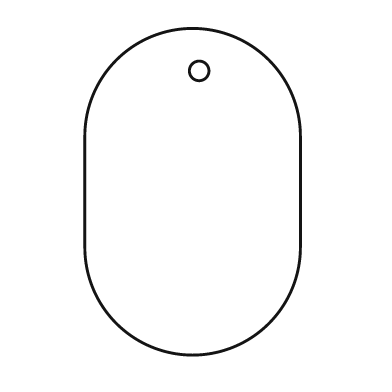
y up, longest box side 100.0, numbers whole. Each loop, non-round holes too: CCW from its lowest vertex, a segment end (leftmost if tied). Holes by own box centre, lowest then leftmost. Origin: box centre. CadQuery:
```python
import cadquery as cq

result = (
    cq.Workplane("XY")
    .moveTo(-33.0, -17.0)
    .threePointArc((0.0, -50.0), (33.0, -17.0))
    .lineTo(33.0, 17.0)
    .threePointArc((0.0, 50.0), (-33.0, 17.0))
    .close()
    .moveTo(2.0, 37.0)
    .circle(3.0)
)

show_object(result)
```